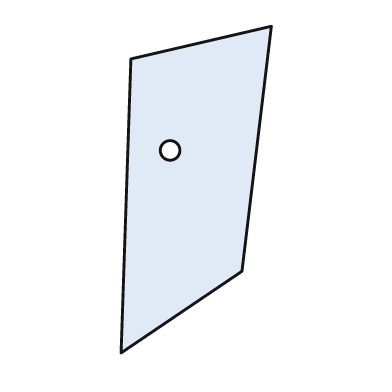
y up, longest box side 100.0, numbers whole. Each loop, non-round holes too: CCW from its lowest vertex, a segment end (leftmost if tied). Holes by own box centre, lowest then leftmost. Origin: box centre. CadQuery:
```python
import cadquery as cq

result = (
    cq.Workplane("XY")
    .moveTo(-23.0, -50.0)
    .lineTo(14.0, -25.0)
    .lineTo(23.0, 50.0)
    .lineTo(-20.0, 40.0)
    .close()
    .moveTo(-8.0, 12.0)
    .circle(3.0)
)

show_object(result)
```